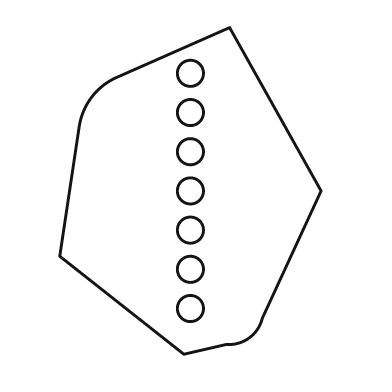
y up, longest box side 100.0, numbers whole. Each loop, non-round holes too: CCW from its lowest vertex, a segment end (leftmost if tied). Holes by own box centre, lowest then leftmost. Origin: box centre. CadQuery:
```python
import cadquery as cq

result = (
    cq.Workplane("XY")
    .moveTo(-2.0, -50.0)
    .lineTo(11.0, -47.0)
    .threePointArc((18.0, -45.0), (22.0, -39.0))
    .lineTo(40.0, 0.0)
    .lineTo(12.0, 50.0)
    .lineTo(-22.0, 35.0)
    .threePointArc((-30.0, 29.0), (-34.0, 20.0))
    .lineTo(-40.0, -20.0)
    .close()
    .moveTo(0.0, -36.0)
    .circle(4.0)
    .moveTo(0.0, -24.0)
    .circle(4.0)
    .moveTo(0.0, -12.0)
    .circle(4.0)
    .moveTo(0.0, 0.0)
    .circle(4.0)
    .moveTo(0.0, 12.0)
    .circle(4.0)
    .moveTo(0.0, 24.0)
    .circle(4.0)
    .moveTo(0.0, 36.0)
    .circle(4.0)
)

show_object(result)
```